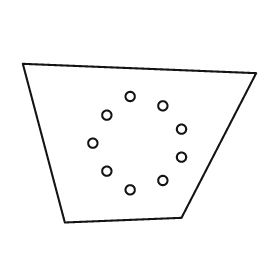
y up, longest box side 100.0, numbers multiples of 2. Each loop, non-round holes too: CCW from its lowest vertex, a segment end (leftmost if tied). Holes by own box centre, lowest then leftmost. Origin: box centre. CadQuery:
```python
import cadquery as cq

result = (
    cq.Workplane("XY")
    .moveTo(-32.0, -34.0)
    .lineTo(18.0, -32.0)
    .lineTo(50.0, 30.0)
    .lineTo(-50.0, 34.0)
    .close()
    .moveTo(-4.0, -20.0)
    .circle(2.0)
    .moveTo(10.0, -16.0)
    .circle(2.0)
    .moveTo(-14.0, -12.0)
    .circle(2.0)
    .moveTo(18.0, -6.0)
    .circle(2.0)
    .moveTo(-20.0, 0.0)
    .circle(2.0)
    .moveTo(18.0, 6.0)
    .circle(2.0)
    .moveTo(-14.0, 12.0)
    .circle(2.0)
    .moveTo(10.0, 16.0)
    .circle(2.0)
    .moveTo(-4.0, 20.0)
    .circle(2.0)
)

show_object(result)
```